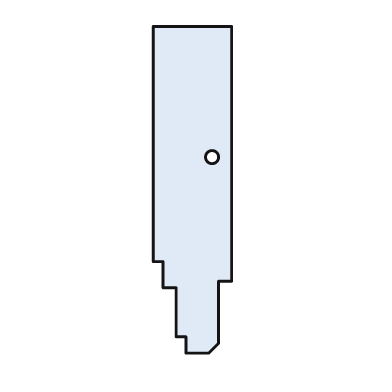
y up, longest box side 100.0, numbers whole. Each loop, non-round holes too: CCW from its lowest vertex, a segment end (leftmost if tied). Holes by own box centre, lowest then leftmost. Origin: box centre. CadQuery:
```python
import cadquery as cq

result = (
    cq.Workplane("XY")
    .moveTo(-2.0, -50.0)
    .lineTo(5.0, -50.0)
    .lineTo(8.0, -47.0)
    .lineTo(8.0, -28.0)
    .lineTo(12.0, -28.0)
    .lineTo(12.0, 50.0)
    .lineTo(-12.0, 50.0)
    .lineTo(-12.0, -22.0)
    .lineTo(-9.0, -22.0)
    .lineTo(-9.0, -30.0)
    .lineTo(-5.0, -30.0)
    .lineTo(-5.0, -45.0)
    .lineTo(-2.0, -45.0)
    .close()
    .moveTo(6.0, 10.0)
    .circle(2.0)
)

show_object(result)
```